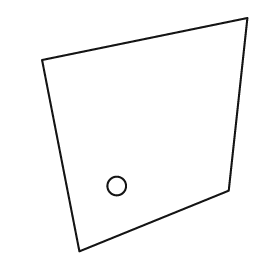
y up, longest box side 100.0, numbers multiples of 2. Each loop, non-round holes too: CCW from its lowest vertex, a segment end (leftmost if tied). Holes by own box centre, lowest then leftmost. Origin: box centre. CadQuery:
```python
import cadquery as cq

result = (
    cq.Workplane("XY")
    .moveTo(-28.0, -50.0)
    .lineTo(36.0, -24.0)
    .lineTo(44.0, 50.0)
    .lineTo(-44.0, 32.0)
    .close()
    .moveTo(-12.0, -22.0)
    .circle(4.0)
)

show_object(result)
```